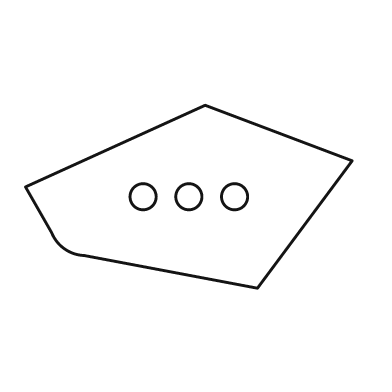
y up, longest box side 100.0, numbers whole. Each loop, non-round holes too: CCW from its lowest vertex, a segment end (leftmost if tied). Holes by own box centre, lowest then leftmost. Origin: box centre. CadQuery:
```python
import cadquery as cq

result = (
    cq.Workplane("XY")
    .moveTo(21.0, -28.0)
    .lineTo(50.0, 11.0)
    .lineTo(5.0, 28.0)
    .lineTo(-50.0, 3.0)
    .lineTo(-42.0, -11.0)
    .threePointArc((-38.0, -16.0), (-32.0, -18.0))
    .close()
    .moveTo(-14.0, 0.0)
    .circle(4.0)
    .moveTo(0.0, 0.0)
    .circle(4.0)
    .moveTo(14.0, 0.0)
    .circle(4.0)
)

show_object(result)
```